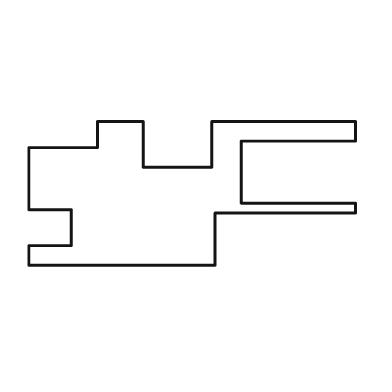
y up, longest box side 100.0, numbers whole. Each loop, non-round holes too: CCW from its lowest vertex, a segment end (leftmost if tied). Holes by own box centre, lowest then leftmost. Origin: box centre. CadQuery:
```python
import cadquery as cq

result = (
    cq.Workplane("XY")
    .moveTo(-50.0, -22.0)
    .lineTo(7.0, -22.0)
    .lineTo(7.0, -6.0)
    .lineTo(50.0, -6.0)
    .lineTo(50.0, -3.0)
    .lineTo(15.0, -3.0)
    .lineTo(15.0, 16.0)
    .lineTo(50.0, 16.0)
    .lineTo(50.0, 22.0)
    .lineTo(6.0, 22.0)
    .lineTo(6.0, 8.0)
    .lineTo(-15.0, 8.0)
    .lineTo(-15.0, 22.0)
    .lineTo(-29.0, 22.0)
    .lineTo(-29.0, 14.0)
    .lineTo(-50.0, 14.0)
    .lineTo(-50.0, -5.0)
    .lineTo(-37.0, -5.0)
    .lineTo(-37.0, -16.0)
    .lineTo(-50.0, -16.0)
    .close()
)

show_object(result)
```